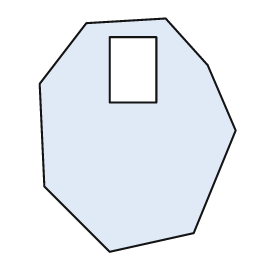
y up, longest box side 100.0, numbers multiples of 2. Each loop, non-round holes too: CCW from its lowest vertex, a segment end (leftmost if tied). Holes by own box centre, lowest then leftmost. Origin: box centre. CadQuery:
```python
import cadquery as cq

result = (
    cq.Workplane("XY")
    .moveTo(-12.0, -50.0)
    .lineTo(24.0, -42.0)
    .lineTo(42.0, 2.0)
    .lineTo(30.0, 30.0)
    .lineTo(12.0, 50.0)
    .lineTo(-22.0, 48.0)
    .lineTo(-42.0, 22.0)
    .lineTo(-40.0, -22.0)
    .close()
    .moveTo(-12.0, 14.0)
    .lineTo(8.0, 14.0)
    .lineTo(8.0, 42.0)
    .lineTo(-12.0, 42.0)
    .close()
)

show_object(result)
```